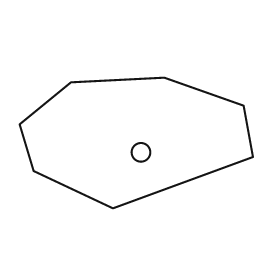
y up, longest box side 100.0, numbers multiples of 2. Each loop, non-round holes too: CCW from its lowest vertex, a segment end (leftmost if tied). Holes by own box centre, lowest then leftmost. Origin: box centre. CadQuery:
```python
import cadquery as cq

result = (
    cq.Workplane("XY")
    .moveTo(-10.0, -28.0)
    .lineTo(50.0, -6.0)
    .lineTo(46.0, 16.0)
    .lineTo(12.0, 28.0)
    .lineTo(-28.0, 26.0)
    .lineTo(-50.0, 8.0)
    .lineTo(-44.0, -12.0)
    .close()
    .moveTo(2.0, -4.0)
    .circle(4.0)
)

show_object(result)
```